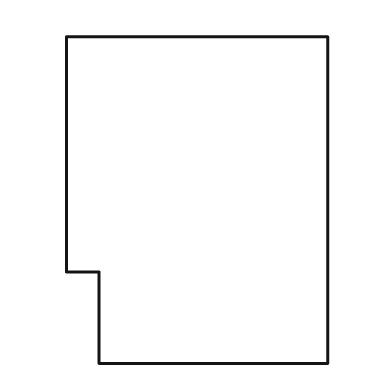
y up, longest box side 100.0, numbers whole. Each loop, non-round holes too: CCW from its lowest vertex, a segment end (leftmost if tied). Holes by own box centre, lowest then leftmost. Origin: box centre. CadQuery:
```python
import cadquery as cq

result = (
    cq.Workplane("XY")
    .moveTo(-30.0, -50.0)
    .lineTo(40.0, -50.0)
    .lineTo(40.0, 50.0)
    .lineTo(-40.0, 50.0)
    .lineTo(-40.0, -22.0)
    .lineTo(-30.0, -22.0)
    .close()
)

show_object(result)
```